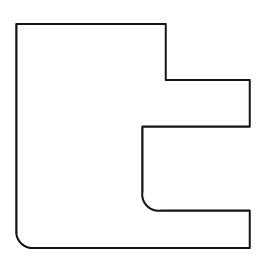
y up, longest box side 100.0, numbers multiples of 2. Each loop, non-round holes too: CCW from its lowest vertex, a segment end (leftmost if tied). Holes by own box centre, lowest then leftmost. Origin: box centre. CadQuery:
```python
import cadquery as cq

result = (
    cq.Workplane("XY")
    .moveTo(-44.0, -48.0)
    .lineTo(50.0, -48.0)
    .lineTo(50.0, -32.0)
    .lineTo(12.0, -32.0)
    .threePointArc((6.0, -30.0), (4.0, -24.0))
    .lineTo(4.0, 4.0)
    .lineTo(50.0, 4.0)
    .lineTo(50.0, 24.0)
    .lineTo(14.0, 24.0)
    .lineTo(14.0, 48.0)
    .lineTo(-50.0, 48.0)
    .lineTo(-50.0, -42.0)
    .threePointArc((-48.0, -46.0), (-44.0, -48.0))
    .close()
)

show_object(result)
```